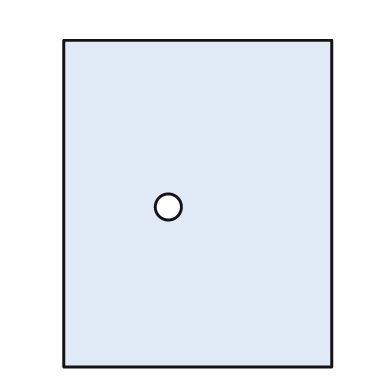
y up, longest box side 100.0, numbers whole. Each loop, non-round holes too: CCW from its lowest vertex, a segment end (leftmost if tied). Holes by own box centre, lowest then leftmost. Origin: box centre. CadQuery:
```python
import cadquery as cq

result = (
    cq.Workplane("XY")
    .moveTo(-41.0, -50.0)
    .lineTo(41.0, -50.0)
    .lineTo(41.0, 50.0)
    .lineTo(-41.0, 50.0)
    .close()
    .moveTo(-9.0, -1.0)
    .circle(4.0)
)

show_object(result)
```